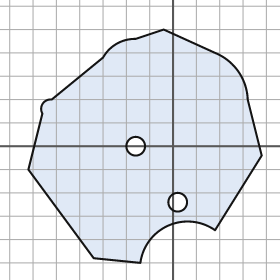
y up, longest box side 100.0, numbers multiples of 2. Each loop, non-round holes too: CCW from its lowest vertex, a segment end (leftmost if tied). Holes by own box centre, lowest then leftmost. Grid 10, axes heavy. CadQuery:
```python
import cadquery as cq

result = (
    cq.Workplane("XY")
    .moveTo(-14.0, -50.0)
    .threePointArc((-2.0, -34.0), (18.0, -36.0))
    .lineTo(38.0, -4.0)
    .lineTo(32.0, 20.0)
    .threePointArc((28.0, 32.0), (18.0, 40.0))
    .lineTo(-4.0, 50.0)
    .lineTo(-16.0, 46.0)
    .threePointArc((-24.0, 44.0), (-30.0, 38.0))
    .lineTo(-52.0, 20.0)
    .threePointArc((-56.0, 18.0), (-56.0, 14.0))
    .lineTo(-62.0, -10.0)
    .lineTo(-34.0, -48.0)
    .close()
    .moveTo(2.0, -24.0)
    .circle(4.0)
    .moveTo(-16.0, 0.0)
    .circle(4.0)
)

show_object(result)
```